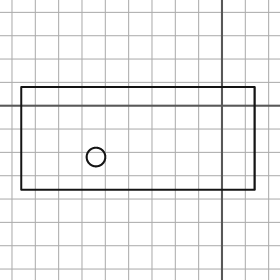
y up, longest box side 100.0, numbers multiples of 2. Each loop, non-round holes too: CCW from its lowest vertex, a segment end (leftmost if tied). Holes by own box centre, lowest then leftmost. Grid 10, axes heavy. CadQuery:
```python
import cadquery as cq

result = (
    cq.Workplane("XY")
    .moveTo(-86.0, -36.0)
    .lineTo(14.0, -36.0)
    .lineTo(14.0, 8.0)
    .lineTo(-86.0, 8.0)
    .close()
    .moveTo(-54.0, -22.0)
    .circle(4.0)
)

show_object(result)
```